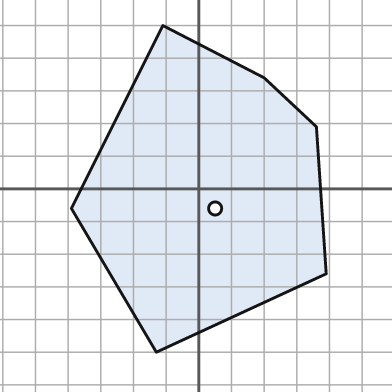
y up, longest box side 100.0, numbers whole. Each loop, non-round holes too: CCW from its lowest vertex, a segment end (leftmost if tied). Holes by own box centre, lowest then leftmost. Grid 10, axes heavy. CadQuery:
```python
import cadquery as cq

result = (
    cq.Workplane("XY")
    .moveTo(-13.0, -50.0)
    .lineTo(39.0, -26.0)
    .lineTo(36.0, 19.0)
    .lineTo(20.0, 34.0)
    .lineTo(-11.0, 50.0)
    .lineTo(-39.0, -6.0)
    .close()
    .moveTo(5.0, -6.0)
    .circle(2.0)
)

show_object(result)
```